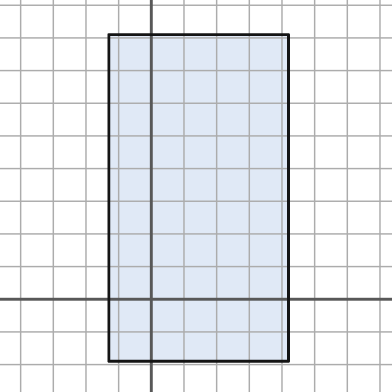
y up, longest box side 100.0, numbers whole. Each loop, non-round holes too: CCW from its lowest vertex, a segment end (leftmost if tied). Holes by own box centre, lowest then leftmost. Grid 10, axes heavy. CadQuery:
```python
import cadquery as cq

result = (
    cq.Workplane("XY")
    .moveTo(-13.0, -19.0)
    .lineTo(42.0, -19.0)
    .lineTo(42.0, 81.0)
    .lineTo(-13.0, 81.0)
    .close()
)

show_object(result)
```